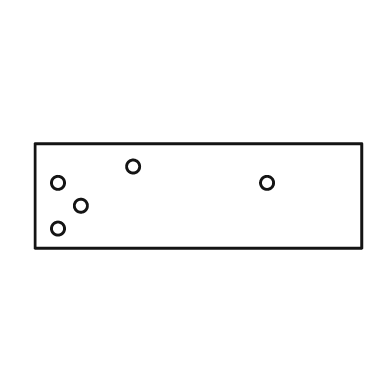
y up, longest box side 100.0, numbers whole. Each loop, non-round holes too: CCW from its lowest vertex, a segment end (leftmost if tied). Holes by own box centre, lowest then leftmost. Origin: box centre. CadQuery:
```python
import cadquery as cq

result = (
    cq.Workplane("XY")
    .moveTo(-50.0, -16.0)
    .lineTo(50.0, -16.0)
    .lineTo(50.0, 16.0)
    .lineTo(-50.0, 16.0)
    .close()
    .moveTo(-43.0, -10.0)
    .circle(2.0)
    .moveTo(-36.0, -3.0)
    .circle(2.0)
    .moveTo(-43.0, 4.0)
    .circle(2.0)
    .moveTo(21.0, 4.0)
    .circle(2.0)
    .moveTo(-20.0, 9.0)
    .circle(2.0)
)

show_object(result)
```